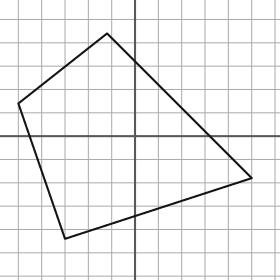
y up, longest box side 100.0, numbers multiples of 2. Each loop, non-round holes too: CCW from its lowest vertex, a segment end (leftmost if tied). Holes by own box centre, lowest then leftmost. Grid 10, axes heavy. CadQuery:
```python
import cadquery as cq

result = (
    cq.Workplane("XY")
    .moveTo(-30.0, -44.0)
    .lineTo(50.0, -18.0)
    .lineTo(-12.0, 44.0)
    .lineTo(-50.0, 14.0)
    .close()
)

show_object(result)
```